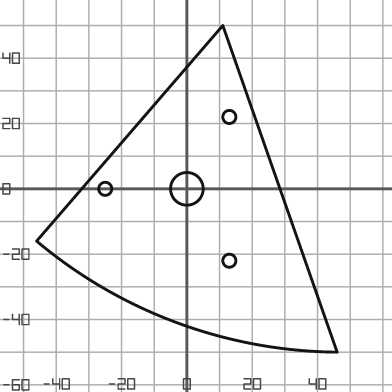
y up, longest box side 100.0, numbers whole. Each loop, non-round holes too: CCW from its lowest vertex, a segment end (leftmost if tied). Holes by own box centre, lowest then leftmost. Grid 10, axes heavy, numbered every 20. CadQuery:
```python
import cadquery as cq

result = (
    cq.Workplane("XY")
    .moveTo(46.0, -50.0)
    .lineTo(11.0, 50.0)
    .lineTo(-46.0, -16.0)
    .threePointArc((-3.0, -41.0), (46.0, -50.0))
    .close()
    .moveTo(13.0, -22.0)
    .circle(2.0)
    .moveTo(-25.0, 0.0)
    .circle(2.0)
    .moveTo(0.0, 0.0)
    .circle(5.0)
    .moveTo(13.0, 22.0)
    .circle(2.0)
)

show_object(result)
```